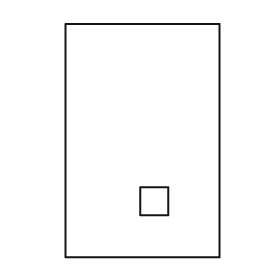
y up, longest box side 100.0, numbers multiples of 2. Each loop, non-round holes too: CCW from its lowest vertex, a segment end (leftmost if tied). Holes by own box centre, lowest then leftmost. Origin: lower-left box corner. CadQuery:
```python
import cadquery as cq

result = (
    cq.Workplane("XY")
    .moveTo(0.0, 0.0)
    .lineTo(66.0, 0.0)
    .lineTo(66.0, 100.0)
    .lineTo(0.0, 100.0)
    .close()
    .moveTo(32.0, 18.0)
    .lineTo(44.0, 18.0)
    .lineTo(44.0, 30.0)
    .lineTo(32.0, 30.0)
    .close()
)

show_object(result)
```